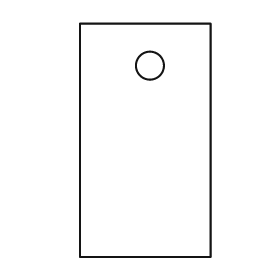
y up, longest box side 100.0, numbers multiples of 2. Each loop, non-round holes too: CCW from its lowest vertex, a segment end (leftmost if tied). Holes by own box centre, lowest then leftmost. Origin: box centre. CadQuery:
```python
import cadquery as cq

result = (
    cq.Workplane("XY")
    .moveTo(-28.0, -50.0)
    .lineTo(28.0, -50.0)
    .lineTo(28.0, 50.0)
    .lineTo(-28.0, 50.0)
    .close()
    .moveTo(2.0, 32.0)
    .circle(6.0)
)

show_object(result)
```